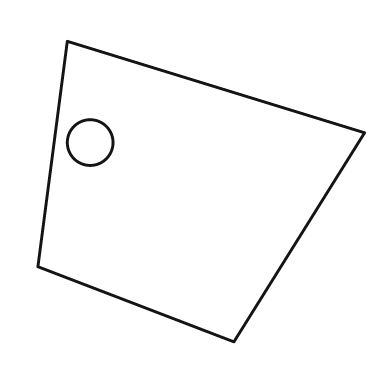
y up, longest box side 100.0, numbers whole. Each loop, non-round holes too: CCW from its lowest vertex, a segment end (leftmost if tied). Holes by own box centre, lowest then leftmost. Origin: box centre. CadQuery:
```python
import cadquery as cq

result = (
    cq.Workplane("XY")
    .moveTo(10.0, -46.0)
    .lineTo(50.0, 18.0)
    .lineTo(-41.0, 46.0)
    .lineTo(-50.0, -23.0)
    .close()
    .moveTo(-34.0, 15.0)
    .circle(7.0)
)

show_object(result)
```